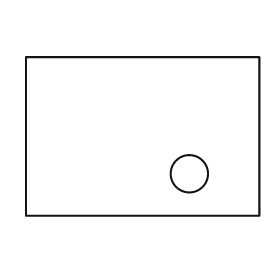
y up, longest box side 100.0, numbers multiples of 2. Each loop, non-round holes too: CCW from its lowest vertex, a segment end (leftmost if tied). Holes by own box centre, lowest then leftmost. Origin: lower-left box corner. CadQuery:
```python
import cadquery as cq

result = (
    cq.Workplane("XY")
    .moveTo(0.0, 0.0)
    .lineTo(100.0, 0.0)
    .lineTo(100.0, 68.0)
    .lineTo(0.0, 68.0)
    .close()
    .moveTo(70.0, 18.0)
    .circle(8.0)
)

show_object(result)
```